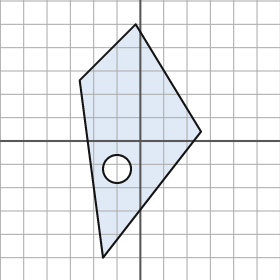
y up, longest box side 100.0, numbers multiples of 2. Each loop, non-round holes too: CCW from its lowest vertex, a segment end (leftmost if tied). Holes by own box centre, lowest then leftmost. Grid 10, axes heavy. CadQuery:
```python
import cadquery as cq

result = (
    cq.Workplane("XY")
    .moveTo(-16.0, -50.0)
    .lineTo(26.0, 4.0)
    .lineTo(-2.0, 50.0)
    .lineTo(-26.0, 26.0)
    .close()
    .moveTo(-10.0, -12.0)
    .circle(6.0)
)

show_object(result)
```